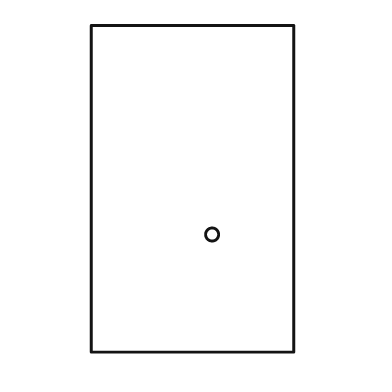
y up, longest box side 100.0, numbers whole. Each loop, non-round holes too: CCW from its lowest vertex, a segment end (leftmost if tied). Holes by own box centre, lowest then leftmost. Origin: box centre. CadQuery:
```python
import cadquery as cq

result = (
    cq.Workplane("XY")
    .moveTo(-31.0, -50.0)
    .lineTo(31.0, -50.0)
    .lineTo(31.0, 50.0)
    .lineTo(-31.0, 50.0)
    .close()
    .moveTo(6.0, -14.0)
    .circle(2.0)
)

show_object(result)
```